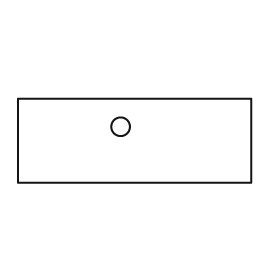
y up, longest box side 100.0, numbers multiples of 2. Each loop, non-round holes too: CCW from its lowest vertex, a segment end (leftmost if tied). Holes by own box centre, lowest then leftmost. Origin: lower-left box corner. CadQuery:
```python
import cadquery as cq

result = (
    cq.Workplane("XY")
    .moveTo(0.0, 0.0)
    .lineTo(100.0, 0.0)
    .lineTo(100.0, 36.0)
    .lineTo(0.0, 36.0)
    .close()
    .moveTo(44.0, 24.0)
    .circle(4.0)
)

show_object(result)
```